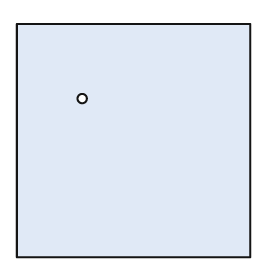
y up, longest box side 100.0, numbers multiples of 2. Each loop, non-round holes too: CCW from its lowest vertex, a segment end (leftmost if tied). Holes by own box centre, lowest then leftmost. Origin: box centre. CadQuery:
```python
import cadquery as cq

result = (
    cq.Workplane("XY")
    .moveTo(-50.0, -50.0)
    .lineTo(50.0, -50.0)
    .lineTo(50.0, 50.0)
    .lineTo(-50.0, 50.0)
    .close()
    .moveTo(-22.0, 18.0)
    .circle(2.0)
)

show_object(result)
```